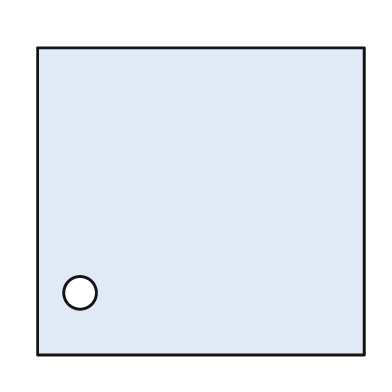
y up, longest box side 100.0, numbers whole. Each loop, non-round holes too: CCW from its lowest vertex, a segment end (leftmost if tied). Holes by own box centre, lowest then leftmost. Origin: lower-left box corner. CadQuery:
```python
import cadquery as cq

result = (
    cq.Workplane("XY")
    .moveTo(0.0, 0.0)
    .lineTo(100.0, 0.0)
    .lineTo(100.0, 94.0)
    .lineTo(0.0, 94.0)
    .close()
    .moveTo(13.0, 19.0)
    .circle(5.0)
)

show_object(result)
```